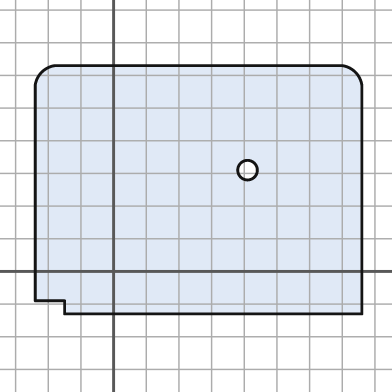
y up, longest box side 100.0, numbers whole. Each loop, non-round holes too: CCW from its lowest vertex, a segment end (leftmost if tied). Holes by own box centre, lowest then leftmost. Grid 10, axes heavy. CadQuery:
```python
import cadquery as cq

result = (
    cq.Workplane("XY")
    .moveTo(-15.0, -13.0)
    .lineTo(76.0, -13.0)
    .lineTo(76.0, 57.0)
    .threePointArc((74.0, 61.0), (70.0, 63.0))
    .lineTo(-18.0, 63.0)
    .threePointArc((-22.0, 61.0), (-24.0, 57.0))
    .lineTo(-24.0, -9.0)
    .lineTo(-15.0, -9.0)
    .close()
    .moveTo(41.0, 31.0)
    .circle(3.0)
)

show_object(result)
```